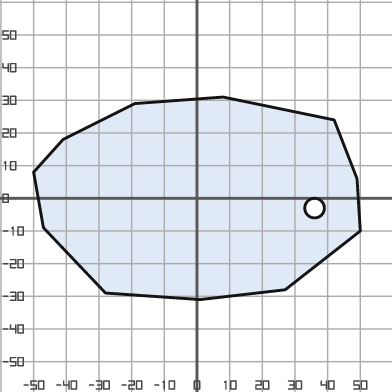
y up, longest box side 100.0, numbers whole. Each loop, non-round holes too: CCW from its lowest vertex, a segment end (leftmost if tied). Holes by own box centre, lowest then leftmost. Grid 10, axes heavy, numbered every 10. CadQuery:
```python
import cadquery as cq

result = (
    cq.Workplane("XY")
    .moveTo(1.0, -31.0)
    .lineTo(27.0, -28.0)
    .lineTo(50.0, -10.0)
    .lineTo(49.0, 6.0)
    .lineTo(42.0, 24.0)
    .lineTo(8.0, 31.0)
    .lineTo(-19.0, 29.0)
    .lineTo(-41.0, 18.0)
    .lineTo(-50.0, 8.0)
    .lineTo(-47.0, -9.0)
    .lineTo(-28.0, -29.0)
    .close()
    .moveTo(36.0, -3.0)
    .circle(3.0)
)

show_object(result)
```